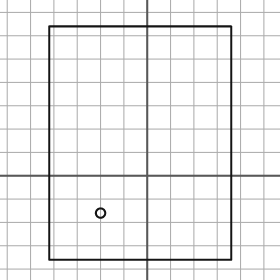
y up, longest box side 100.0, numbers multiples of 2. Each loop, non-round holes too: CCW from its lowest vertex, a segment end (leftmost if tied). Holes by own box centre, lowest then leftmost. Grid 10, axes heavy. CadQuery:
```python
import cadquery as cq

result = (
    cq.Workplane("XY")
    .moveTo(-42.0, -36.0)
    .lineTo(36.0, -36.0)
    .lineTo(36.0, 64.0)
    .lineTo(-42.0, 64.0)
    .close()
    .moveTo(-20.0, -16.0)
    .circle(2.0)
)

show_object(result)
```